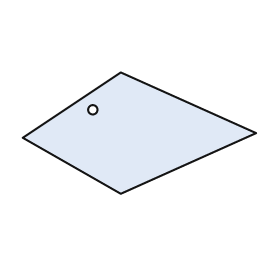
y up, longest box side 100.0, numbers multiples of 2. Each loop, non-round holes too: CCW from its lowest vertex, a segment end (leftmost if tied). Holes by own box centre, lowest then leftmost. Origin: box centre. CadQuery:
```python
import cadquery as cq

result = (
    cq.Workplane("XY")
    .moveTo(-8.0, -26.0)
    .lineTo(50.0, 0.0)
    .lineTo(-8.0, 26.0)
    .lineTo(-50.0, -2.0)
    .close()
    .moveTo(-20.0, 10.0)
    .circle(2.0)
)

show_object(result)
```